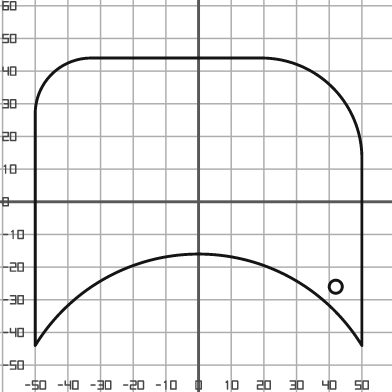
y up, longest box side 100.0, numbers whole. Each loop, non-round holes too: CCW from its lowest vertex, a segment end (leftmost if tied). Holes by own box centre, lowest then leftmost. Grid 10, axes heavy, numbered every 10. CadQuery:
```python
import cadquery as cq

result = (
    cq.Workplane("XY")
    .moveTo(-50.0, -44.0)
    .threePointArc((0.0, -16.0), (50.0, -44.0))
    .lineTo(50.0, 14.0)
    .threePointArc((41.0, 35.0), (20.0, 44.0))
    .lineTo(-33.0, 44.0)
    .threePointArc((-45.0, 39.0), (-50.0, 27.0))
    .close()
    .moveTo(42.0, -26.0)
    .circle(2.0)
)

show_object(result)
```